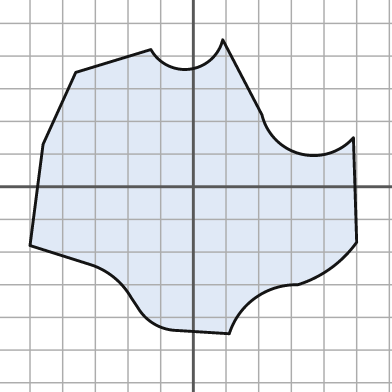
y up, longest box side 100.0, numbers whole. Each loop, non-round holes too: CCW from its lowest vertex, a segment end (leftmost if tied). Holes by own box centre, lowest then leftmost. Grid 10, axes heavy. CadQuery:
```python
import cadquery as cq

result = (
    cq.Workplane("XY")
    .moveTo(11.0, -45.0)
    .threePointArc((19.0, -34.0), (32.0, -30.0))
    .threePointArc((42.0, -25.0), (50.0, -17.0))
    .lineTo(49.0, 15.0)
    .threePointArc((33.0, 10.0), (21.0, 22.0))
    .lineTo(9.0, 45.0)
    .threePointArc((-1.0, 36.0), (-13.0, 42.0))
    .lineTo(-36.0, 35.0)
    .lineTo(-46.0, 13.0)
    .lineTo(-50.0, -18.0)
    .lineTo(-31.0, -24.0)
    .threePointArc((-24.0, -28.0), (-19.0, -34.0))
    .lineTo(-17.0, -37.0)
    .threePointArc((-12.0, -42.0), (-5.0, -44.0))
    .close()
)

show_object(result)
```